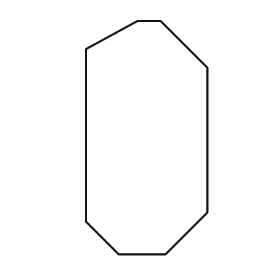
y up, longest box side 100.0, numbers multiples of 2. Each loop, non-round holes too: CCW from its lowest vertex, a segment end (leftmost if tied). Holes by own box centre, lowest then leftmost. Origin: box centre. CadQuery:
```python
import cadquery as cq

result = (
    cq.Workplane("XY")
    .moveTo(-12.0, -50.0)
    .lineTo(8.0, -50.0)
    .lineTo(26.0, -32.0)
    .lineTo(26.0, 30.0)
    .lineTo(6.0, 50.0)
    .lineTo(-4.0, 50.0)
    .lineTo(-26.0, 38.0)
    .lineTo(-26.0, -36.0)
    .close()
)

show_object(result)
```